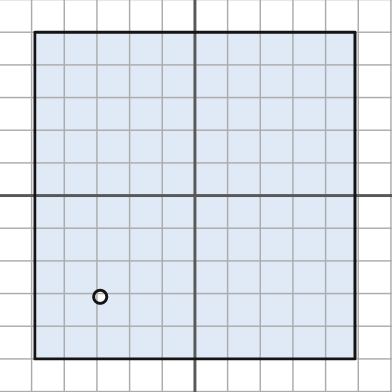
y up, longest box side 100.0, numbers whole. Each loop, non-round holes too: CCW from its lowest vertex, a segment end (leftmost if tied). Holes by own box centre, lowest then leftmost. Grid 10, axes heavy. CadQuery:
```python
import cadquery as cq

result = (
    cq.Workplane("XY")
    .moveTo(-49.0, -50.0)
    .lineTo(49.0, -50.0)
    .lineTo(49.0, 50.0)
    .lineTo(-49.0, 50.0)
    .close()
    .moveTo(-29.0, -31.0)
    .circle(2.0)
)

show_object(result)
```